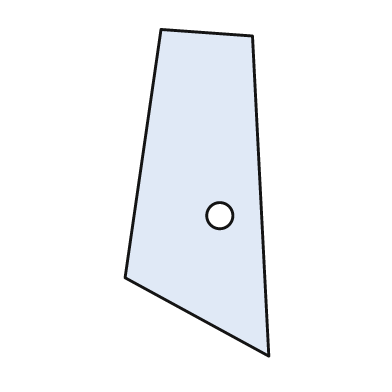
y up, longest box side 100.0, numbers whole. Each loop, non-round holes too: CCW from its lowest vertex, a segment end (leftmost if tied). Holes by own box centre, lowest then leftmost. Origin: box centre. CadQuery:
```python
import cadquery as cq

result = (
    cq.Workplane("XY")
    .moveTo(22.0, -50.0)
    .lineTo(17.0, 48.0)
    .lineTo(-11.0, 50.0)
    .lineTo(-22.0, -26.0)
    .close()
    .moveTo(7.0, -7.0)
    .circle(4.0)
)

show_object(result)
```